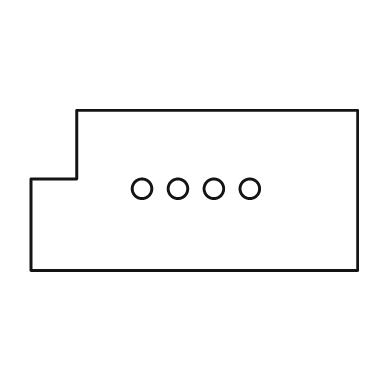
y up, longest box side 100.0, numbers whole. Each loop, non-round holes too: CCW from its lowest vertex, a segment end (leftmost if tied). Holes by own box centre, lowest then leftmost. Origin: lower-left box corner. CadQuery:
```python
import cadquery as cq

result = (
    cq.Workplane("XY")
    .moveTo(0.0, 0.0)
    .lineTo(100.0, 0.0)
    .lineTo(100.0, 49.0)
    .lineTo(14.0, 49.0)
    .lineTo(14.0, 28.0)
    .lineTo(0.0, 28.0)
    .close()
    .moveTo(34.0, 25.0)
    .circle(3.0)
    .moveTo(45.0, 25.0)
    .circle(3.0)
    .moveTo(56.0, 25.0)
    .circle(3.0)
    .moveTo(67.0, 25.0)
    .circle(3.0)
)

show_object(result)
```